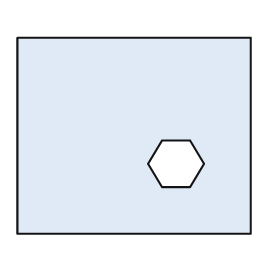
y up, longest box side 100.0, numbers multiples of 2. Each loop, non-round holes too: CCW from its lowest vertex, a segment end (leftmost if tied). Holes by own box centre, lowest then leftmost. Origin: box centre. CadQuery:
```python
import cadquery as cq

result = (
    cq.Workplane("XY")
    .moveTo(-50.0, -42.0)
    .lineTo(50.0, -42.0)
    .lineTo(50.0, 42.0)
    .lineTo(-50.0, 42.0)
    .close()
    .moveTo(12.0, -22.0)
    .lineTo(24.0, -22.0)
    .lineTo(30.0, -12.0)
    .lineTo(24.0, -2.0)
    .lineTo(12.0, -2.0)
    .lineTo(6.0, -12.0)
    .close()
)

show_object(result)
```